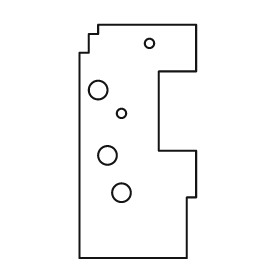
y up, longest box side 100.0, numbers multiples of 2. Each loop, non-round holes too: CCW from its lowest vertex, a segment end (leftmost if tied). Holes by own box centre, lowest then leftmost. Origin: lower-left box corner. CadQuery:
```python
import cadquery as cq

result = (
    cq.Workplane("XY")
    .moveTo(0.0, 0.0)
    .lineTo(46.0, 0.0)
    .lineTo(46.0, 26.0)
    .lineTo(50.0, 26.0)
    .lineTo(50.0, 46.0)
    .lineTo(34.0, 46.0)
    .lineTo(34.0, 80.0)
    .lineTo(50.0, 80.0)
    .lineTo(50.0, 100.0)
    .lineTo(8.0, 100.0)
    .lineTo(8.0, 96.0)
    .lineTo(4.0, 96.0)
    .lineTo(4.0, 88.0)
    .lineTo(0.0, 88.0)
    .close()
    .moveTo(18.0, 28.0)
    .circle(4.0)
    .moveTo(12.0, 44.0)
    .circle(4.0)
    .moveTo(18.0, 62.0)
    .circle(2.0)
    .moveTo(8.0, 72.0)
    .circle(4.0)
    .moveTo(30.0, 92.0)
    .circle(2.0)
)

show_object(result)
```